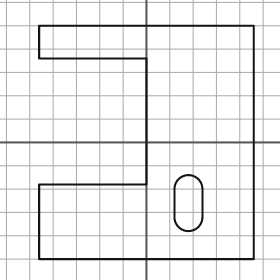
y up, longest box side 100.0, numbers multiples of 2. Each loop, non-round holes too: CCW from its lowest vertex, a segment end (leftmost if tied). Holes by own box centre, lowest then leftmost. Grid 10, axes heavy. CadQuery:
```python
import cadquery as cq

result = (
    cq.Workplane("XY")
    .moveTo(-46.0, -50.0)
    .lineTo(46.0, -50.0)
    .lineTo(46.0, 50.0)
    .lineTo(-46.0, 50.0)
    .lineTo(-46.0, 36.0)
    .lineTo(0.0, 36.0)
    .lineTo(0.0, -18.0)
    .lineTo(-46.0, -18.0)
    .close()
    .moveTo(12.0, -32.0)
    .threePointArc((18.0, -38.0), (24.0, -32.0))
    .lineTo(24.0, -20.0)
    .threePointArc((18.0, -14.0), (12.0, -20.0))
    .close()
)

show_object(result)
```